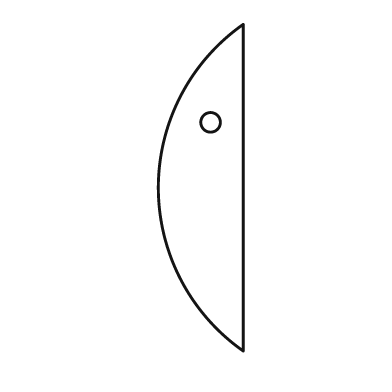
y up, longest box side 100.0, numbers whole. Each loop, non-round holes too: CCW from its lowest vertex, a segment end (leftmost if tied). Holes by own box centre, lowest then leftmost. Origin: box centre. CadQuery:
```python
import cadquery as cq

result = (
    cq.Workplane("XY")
    .moveTo(13.0, -50.0)
    .lineTo(13.0, 50.0)
    .threePointArc((-13.0, 0.0), (13.0, -50.0))
    .close()
    .moveTo(3.0, 20.0)
    .circle(3.0)
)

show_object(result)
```